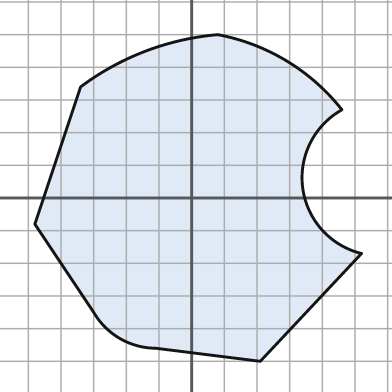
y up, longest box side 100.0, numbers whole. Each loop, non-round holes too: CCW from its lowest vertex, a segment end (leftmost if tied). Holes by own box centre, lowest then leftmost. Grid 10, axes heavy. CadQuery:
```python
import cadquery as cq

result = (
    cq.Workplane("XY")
    .moveTo(21.0, -50.0)
    .lineTo(52.0, -17.0)
    .threePointArc((34.0, 3.0), (46.0, 27.0))
    .threePointArc((29.0, 42.0), (8.0, 50.0))
    .threePointArc((-14.0, 45.0), (-34.0, 34.0))
    .lineTo(-48.0, -8.0)
    .lineTo(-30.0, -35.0)
    .threePointArc((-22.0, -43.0), (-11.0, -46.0))
    .close()
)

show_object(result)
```